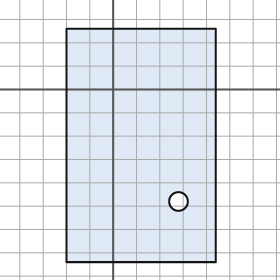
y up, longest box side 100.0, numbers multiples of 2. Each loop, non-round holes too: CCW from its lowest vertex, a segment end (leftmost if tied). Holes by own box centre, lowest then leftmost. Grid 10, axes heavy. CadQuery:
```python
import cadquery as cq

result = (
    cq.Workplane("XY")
    .moveTo(-20.0, -74.0)
    .lineTo(44.0, -74.0)
    .lineTo(44.0, 26.0)
    .lineTo(-20.0, 26.0)
    .close()
    .moveTo(28.0, -48.0)
    .circle(4.0)
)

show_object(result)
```